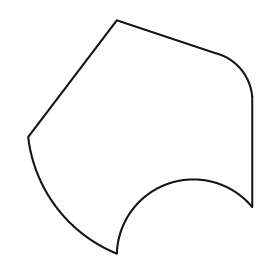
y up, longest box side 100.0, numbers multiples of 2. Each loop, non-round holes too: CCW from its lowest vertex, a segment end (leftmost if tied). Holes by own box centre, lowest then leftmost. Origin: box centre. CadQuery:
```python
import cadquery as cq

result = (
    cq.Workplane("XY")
    .moveTo(-10.0, -50.0)
    .threePointArc((12.0, -20.0), (48.0, -30.0))
    .lineTo(48.0, 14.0)
    .threePointArc((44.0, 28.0), (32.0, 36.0))
    .lineTo(-10.0, 50.0)
    .lineTo(-48.0, 0.0)
    .threePointArc((-36.0, -30.0), (-10.0, -50.0))
    .close()
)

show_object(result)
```